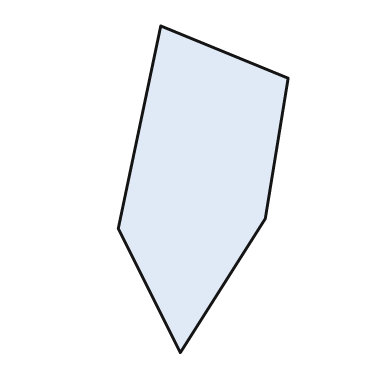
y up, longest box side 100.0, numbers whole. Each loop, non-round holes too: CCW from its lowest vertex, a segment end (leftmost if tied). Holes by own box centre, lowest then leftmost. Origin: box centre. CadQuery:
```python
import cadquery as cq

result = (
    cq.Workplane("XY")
    .moveTo(-7.0, -50.0)
    .lineTo(19.0, -9.0)
    .lineTo(26.0, 34.0)
    .lineTo(-13.0, 50.0)
    .lineTo(-26.0, -12.0)
    .close()
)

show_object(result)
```